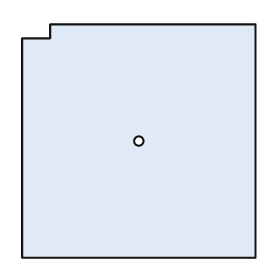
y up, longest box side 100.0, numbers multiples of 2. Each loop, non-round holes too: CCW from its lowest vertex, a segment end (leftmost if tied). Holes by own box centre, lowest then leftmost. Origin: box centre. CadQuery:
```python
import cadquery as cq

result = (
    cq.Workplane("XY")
    .moveTo(-50.0, -50.0)
    .lineTo(50.0, -50.0)
    .lineTo(50.0, 50.0)
    .lineTo(-38.0, 50.0)
    .lineTo(-38.0, 44.0)
    .lineTo(-50.0, 44.0)
    .close()
    .moveTo(0.0, 0.0)
    .circle(2.0)
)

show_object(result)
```